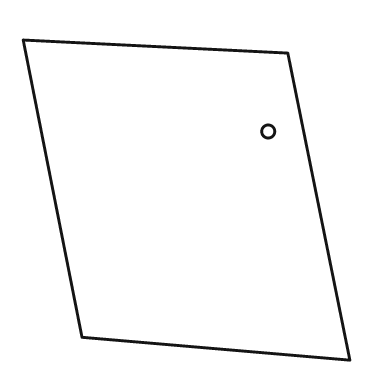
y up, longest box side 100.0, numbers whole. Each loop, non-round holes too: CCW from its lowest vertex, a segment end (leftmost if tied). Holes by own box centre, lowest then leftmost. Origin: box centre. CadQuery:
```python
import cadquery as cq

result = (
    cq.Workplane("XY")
    .moveTo(50.0, -49.0)
    .lineTo(31.0, 45.0)
    .lineTo(-50.0, 49.0)
    .lineTo(-32.0, -42.0)
    .close()
    .moveTo(25.0, 21.0)
    .circle(2.0)
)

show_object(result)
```